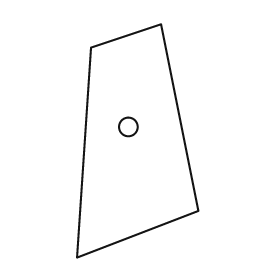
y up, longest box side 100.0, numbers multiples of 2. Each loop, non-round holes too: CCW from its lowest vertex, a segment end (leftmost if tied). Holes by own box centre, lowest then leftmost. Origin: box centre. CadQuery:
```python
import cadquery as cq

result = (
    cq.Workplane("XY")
    .moveTo(-26.0, -50.0)
    .lineTo(26.0, -30.0)
    .lineTo(10.0, 50.0)
    .lineTo(-20.0, 40.0)
    .close()
    .moveTo(-4.0, 6.0)
    .circle(4.0)
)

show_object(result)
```